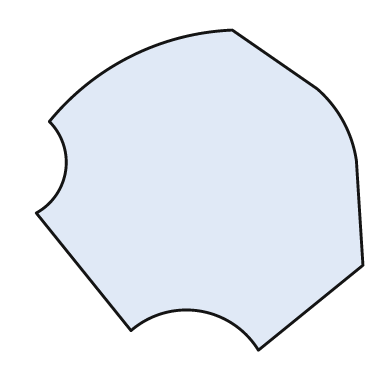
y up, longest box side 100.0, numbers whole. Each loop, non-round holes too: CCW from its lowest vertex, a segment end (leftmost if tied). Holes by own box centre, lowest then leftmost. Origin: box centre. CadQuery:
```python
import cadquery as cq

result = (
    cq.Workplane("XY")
    .moveTo(18.0, -49.0)
    .lineTo(50.0, -23.0)
    .lineTo(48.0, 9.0)
    .threePointArc((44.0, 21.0), (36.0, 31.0))
    .lineTo(10.0, 49.0)
    .threePointArc((-21.0, 41.0), (-46.0, 21.0))
    .threePointArc((-41.0, 6.0), (-50.0, -7.0))
    .lineTo(-21.0, -43.0)
    .threePointArc((0.0, -37.0), (18.0, -49.0))
    .close()
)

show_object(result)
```